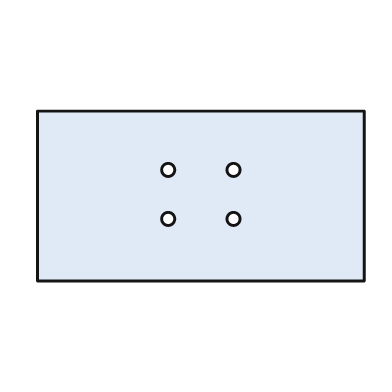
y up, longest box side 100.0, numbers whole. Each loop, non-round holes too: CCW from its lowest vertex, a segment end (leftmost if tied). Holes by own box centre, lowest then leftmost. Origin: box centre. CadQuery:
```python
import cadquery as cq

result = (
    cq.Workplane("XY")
    .moveTo(-50.0, -26.0)
    .lineTo(50.0, -26.0)
    .lineTo(50.0, 26.0)
    .lineTo(-50.0, 26.0)
    .close()
    .moveTo(-10.0, -7.0)
    .circle(2.0)
    .moveTo(10.0, -7.0)
    .circle(2.0)
    .moveTo(-10.0, 8.0)
    .circle(2.0)
    .moveTo(10.0, 8.0)
    .circle(2.0)
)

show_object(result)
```